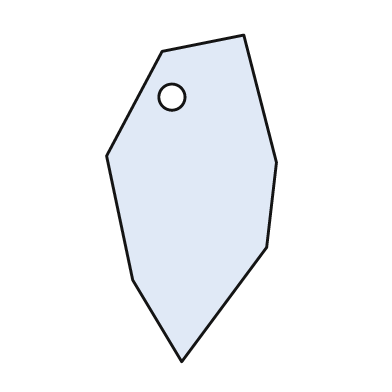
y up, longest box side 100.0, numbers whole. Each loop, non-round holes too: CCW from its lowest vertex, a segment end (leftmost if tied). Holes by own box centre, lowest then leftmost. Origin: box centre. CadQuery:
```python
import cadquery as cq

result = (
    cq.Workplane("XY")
    .moveTo(-3.0, -50.0)
    .lineTo(23.0, -15.0)
    .lineTo(26.0, 11.0)
    .lineTo(16.0, 50.0)
    .lineTo(-9.0, 45.0)
    .lineTo(-26.0, 13.0)
    .lineTo(-18.0, -25.0)
    .close()
    .moveTo(-6.0, 31.0)
    .circle(4.0)
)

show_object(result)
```